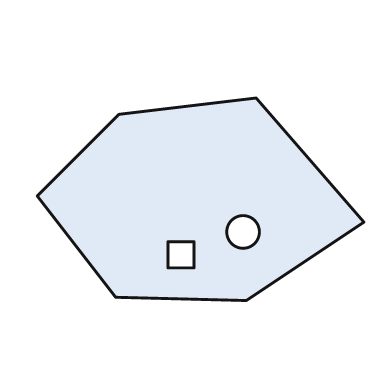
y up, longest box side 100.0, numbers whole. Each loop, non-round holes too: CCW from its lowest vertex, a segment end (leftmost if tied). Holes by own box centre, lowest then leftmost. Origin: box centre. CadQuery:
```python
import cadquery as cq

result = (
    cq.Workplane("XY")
    .moveTo(14.0, -31.0)
    .lineTo(50.0, -7.0)
    .lineTo(17.0, 31.0)
    .lineTo(-25.0, 26.0)
    .lineTo(-50.0, 1.0)
    .lineTo(-26.0, -30.0)
    .close()
    .moveTo(-10.0, -21.0)
    .lineTo(-2.0, -21.0)
    .lineTo(-2.0, -13.0)
    .lineTo(-10.0, -13.0)
    .close()
    .moveTo(13.0, -10.0)
    .circle(5.0)
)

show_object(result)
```